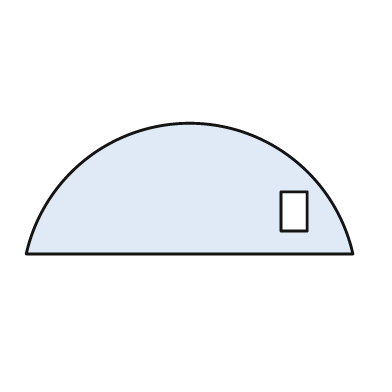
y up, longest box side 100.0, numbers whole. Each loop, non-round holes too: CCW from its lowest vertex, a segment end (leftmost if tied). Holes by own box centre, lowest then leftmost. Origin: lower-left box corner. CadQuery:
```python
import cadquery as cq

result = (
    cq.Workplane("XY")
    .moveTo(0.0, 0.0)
    .lineTo(100.0, 0.0)
    .threePointArc((50.0, 40.0), (0.0, 0.0))
    .close()
    .moveTo(78.0, 7.0)
    .lineTo(86.0, 7.0)
    .lineTo(86.0, 19.0)
    .lineTo(78.0, 19.0)
    .close()
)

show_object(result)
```